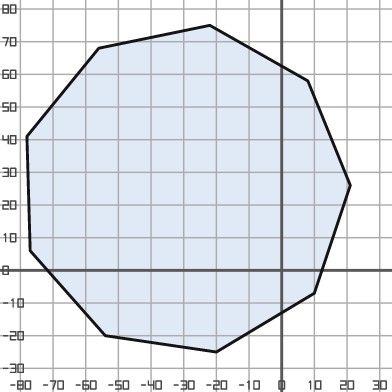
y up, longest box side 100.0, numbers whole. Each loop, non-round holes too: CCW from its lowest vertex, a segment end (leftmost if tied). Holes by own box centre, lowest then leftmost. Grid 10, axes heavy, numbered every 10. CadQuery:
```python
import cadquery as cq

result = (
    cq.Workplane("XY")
    .moveTo(-20.0, -25.0)
    .lineTo(10.0, -7.0)
    .lineTo(21.0, 26.0)
    .lineTo(8.0, 58.0)
    .lineTo(-22.0, 75.0)
    .lineTo(-56.0, 68.0)
    .lineTo(-78.0, 41.0)
    .lineTo(-77.0, 6.0)
    .lineTo(-54.0, -20.0)
    .close()
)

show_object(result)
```